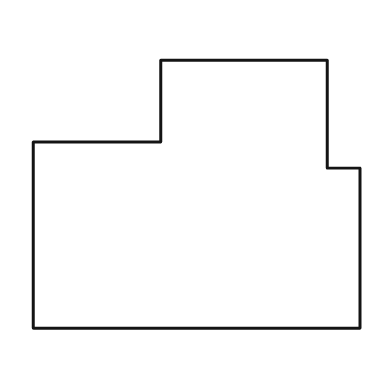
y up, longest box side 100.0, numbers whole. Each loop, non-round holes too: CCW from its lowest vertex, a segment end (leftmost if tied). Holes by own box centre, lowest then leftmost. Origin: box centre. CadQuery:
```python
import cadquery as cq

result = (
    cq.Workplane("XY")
    .moveTo(-50.0, -41.0)
    .lineTo(50.0, -41.0)
    .lineTo(50.0, 8.0)
    .lineTo(40.0, 8.0)
    .lineTo(40.0, 41.0)
    .lineTo(-11.0, 41.0)
    .lineTo(-11.0, 16.0)
    .lineTo(-50.0, 16.0)
    .close()
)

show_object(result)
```